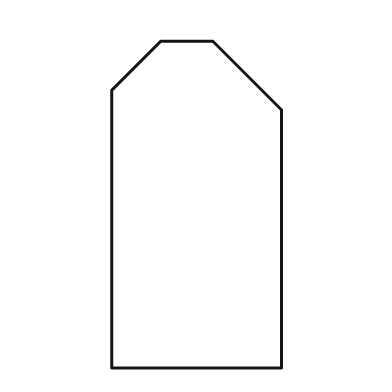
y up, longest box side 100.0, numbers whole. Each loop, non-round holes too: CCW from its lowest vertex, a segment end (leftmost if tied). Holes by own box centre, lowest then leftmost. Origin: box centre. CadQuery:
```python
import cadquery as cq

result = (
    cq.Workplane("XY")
    .moveTo(-26.0, -50.0)
    .lineTo(26.0, -50.0)
    .lineTo(26.0, 29.0)
    .lineTo(5.0, 50.0)
    .lineTo(-11.0, 50.0)
    .lineTo(-26.0, 35.0)
    .close()
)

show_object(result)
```